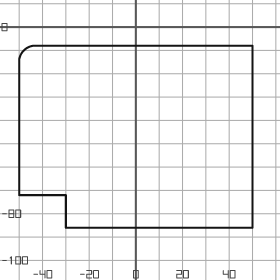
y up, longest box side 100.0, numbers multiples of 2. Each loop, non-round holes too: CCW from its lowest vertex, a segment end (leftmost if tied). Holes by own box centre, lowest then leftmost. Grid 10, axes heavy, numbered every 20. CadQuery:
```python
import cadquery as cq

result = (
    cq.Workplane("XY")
    .moveTo(-30.0, -86.0)
    .lineTo(50.0, -86.0)
    .lineTo(50.0, -8.0)
    .lineTo(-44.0, -8.0)
    .threePointArc((-48.0, -10.0), (-50.0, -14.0))
    .lineTo(-50.0, -72.0)
    .lineTo(-30.0, -72.0)
    .close()
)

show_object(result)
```